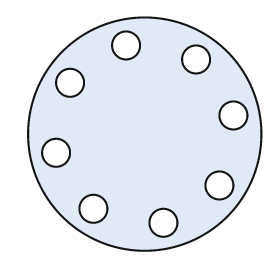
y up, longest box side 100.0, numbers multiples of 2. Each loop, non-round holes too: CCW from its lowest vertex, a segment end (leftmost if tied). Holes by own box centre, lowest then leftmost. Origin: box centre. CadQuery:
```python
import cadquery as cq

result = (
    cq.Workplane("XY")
    .moveTo(0.0, 0.0)
    .circle(50.0)
    .moveTo(8.0, -38.0)
    .circle(6.0)
    .moveTo(-22.0, -32.0)
    .circle(6.0)
    .moveTo(32.0, -22.0)
    .circle(6.0)
    .moveTo(-38.0, -8.0)
    .circle(6.0)
    .moveTo(38.0, 8.0)
    .circle(6.0)
    .moveTo(-32.0, 22.0)
    .circle(6.0)
    .moveTo(22.0, 32.0)
    .circle(6.0)
    .moveTo(-8.0, 38.0)
    .circle(6.0)
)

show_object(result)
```